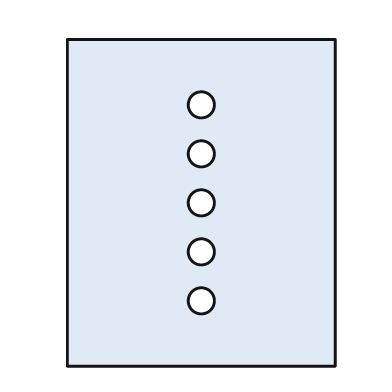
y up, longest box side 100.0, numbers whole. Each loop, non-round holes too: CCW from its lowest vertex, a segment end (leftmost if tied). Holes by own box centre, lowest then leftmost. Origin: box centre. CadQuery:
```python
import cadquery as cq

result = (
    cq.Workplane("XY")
    .moveTo(-41.0, -50.0)
    .lineTo(41.0, -50.0)
    .lineTo(41.0, 50.0)
    .lineTo(-41.0, 50.0)
    .close()
    .moveTo(0.0, -30.0)
    .circle(4.0)
    .moveTo(0.0, -15.0)
    .circle(4.0)
    .moveTo(0.0, 0.0)
    .circle(4.0)
    .moveTo(0.0, 15.0)
    .circle(4.0)
    .moveTo(0.0, 30.0)
    .circle(4.0)
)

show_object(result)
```